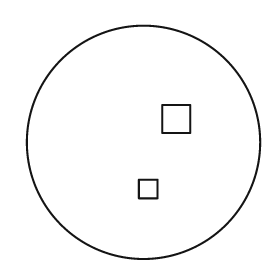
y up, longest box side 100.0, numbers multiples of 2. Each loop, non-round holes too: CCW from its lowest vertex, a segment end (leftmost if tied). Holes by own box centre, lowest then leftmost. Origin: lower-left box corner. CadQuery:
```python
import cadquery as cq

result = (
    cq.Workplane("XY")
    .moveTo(50.0, 50.0)
    .circle(50.0)
    .moveTo(48.0, 26.0)
    .lineTo(56.0, 26.0)
    .lineTo(56.0, 34.0)
    .lineTo(48.0, 34.0)
    .close()
    .moveTo(58.0, 54.0)
    .lineTo(70.0, 54.0)
    .lineTo(70.0, 66.0)
    .lineTo(58.0, 66.0)
    .close()
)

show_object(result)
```